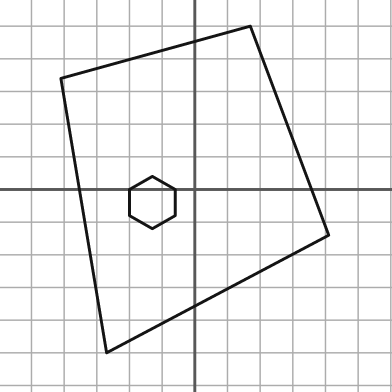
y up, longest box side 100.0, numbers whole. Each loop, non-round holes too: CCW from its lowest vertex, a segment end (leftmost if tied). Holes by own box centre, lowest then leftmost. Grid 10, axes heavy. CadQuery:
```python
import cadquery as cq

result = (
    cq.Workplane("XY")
    .moveTo(-27.0, -50.0)
    .lineTo(41.0, -14.0)
    .lineTo(17.0, 50.0)
    .lineTo(-41.0, 34.0)
    .close()
    .moveTo(-13.0, -12.0)
    .lineTo(-6.0, -8.0)
    .lineTo(-6.0, 0.0)
    .lineTo(-13.0, 4.0)
    .lineTo(-20.0, 0.0)
    .lineTo(-20.0, -8.0)
    .close()
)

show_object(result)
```